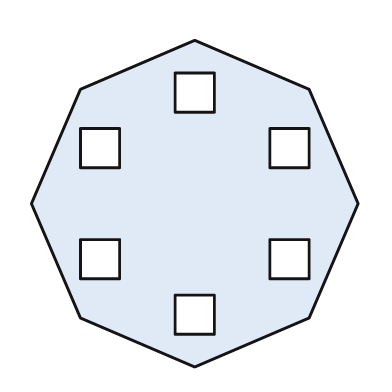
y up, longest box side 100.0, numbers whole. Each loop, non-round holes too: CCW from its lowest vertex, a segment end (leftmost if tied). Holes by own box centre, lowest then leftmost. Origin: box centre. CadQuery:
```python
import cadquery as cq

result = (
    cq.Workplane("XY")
    .moveTo(0.0, -50.0)
    .lineTo(35.0, -35.0)
    .lineTo(50.0, 0.0)
    .lineTo(35.0, 35.0)
    .lineTo(0.0, 50.0)
    .lineTo(-35.0, 35.0)
    .lineTo(-50.0, 0.0)
    .lineTo(-35.0, -35.0)
    .close()
    .moveTo(-6.0, -40.0)
    .lineTo(6.0, -40.0)
    .lineTo(6.0, -28.0)
    .lineTo(-6.0, -28.0)
    .close()
    .moveTo(-35.0, -23.0)
    .lineTo(-23.0, -23.0)
    .lineTo(-23.0, -11.0)
    .lineTo(-35.0, -11.0)
    .close()
    .moveTo(23.0, -23.0)
    .lineTo(35.0, -23.0)
    .lineTo(35.0, -11.0)
    .lineTo(23.0, -11.0)
    .close()
    .moveTo(-35.0, 11.0)
    .lineTo(-23.0, 11.0)
    .lineTo(-23.0, 23.0)
    .lineTo(-35.0, 23.0)
    .close()
    .moveTo(23.0, 11.0)
    .lineTo(35.0, 11.0)
    .lineTo(35.0, 23.0)
    .lineTo(23.0, 23.0)
    .close()
    .moveTo(-6.0, 28.0)
    .lineTo(6.0, 28.0)
    .lineTo(6.0, 40.0)
    .lineTo(-6.0, 40.0)
    .close()
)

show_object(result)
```